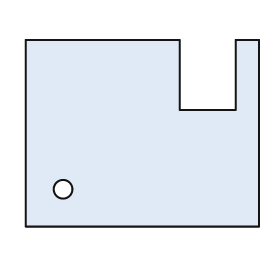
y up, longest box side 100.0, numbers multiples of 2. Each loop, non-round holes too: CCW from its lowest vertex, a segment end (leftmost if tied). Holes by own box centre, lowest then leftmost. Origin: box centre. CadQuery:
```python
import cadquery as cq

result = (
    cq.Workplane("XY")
    .moveTo(-50.0, -40.0)
    .lineTo(50.0, -40.0)
    .lineTo(50.0, 40.0)
    .lineTo(40.0, 40.0)
    .lineTo(40.0, 10.0)
    .lineTo(16.0, 10.0)
    .lineTo(16.0, 40.0)
    .lineTo(-50.0, 40.0)
    .close()
    .moveTo(-34.0, -24.0)
    .circle(4.0)
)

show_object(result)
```